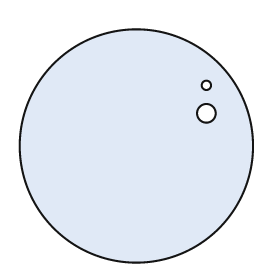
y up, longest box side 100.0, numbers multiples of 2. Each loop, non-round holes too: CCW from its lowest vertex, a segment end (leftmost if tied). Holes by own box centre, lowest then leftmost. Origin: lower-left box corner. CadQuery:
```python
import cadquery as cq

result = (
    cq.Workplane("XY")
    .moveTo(50.0, 50.0)
    .circle(50.0)
    .moveTo(80.0, 64.0)
    .circle(4.0)
    .moveTo(80.0, 76.0)
    .circle(2.0)
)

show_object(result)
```